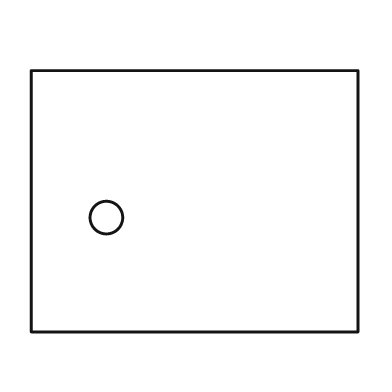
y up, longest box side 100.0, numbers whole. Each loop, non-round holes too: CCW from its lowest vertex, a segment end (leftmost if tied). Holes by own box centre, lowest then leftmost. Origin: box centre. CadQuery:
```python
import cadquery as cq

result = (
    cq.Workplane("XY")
    .moveTo(-50.0, -40.0)
    .lineTo(50.0, -40.0)
    .lineTo(50.0, 40.0)
    .lineTo(-50.0, 40.0)
    .close()
    .moveTo(-27.0, -5.0)
    .circle(5.0)
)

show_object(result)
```